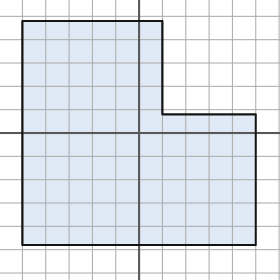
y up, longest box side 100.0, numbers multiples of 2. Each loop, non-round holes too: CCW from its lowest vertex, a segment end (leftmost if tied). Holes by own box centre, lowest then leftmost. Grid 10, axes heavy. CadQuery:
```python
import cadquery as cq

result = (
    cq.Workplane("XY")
    .moveTo(-50.0, -48.0)
    .lineTo(50.0, -48.0)
    .lineTo(50.0, 8.0)
    .lineTo(10.0, 8.0)
    .lineTo(10.0, 48.0)
    .lineTo(-50.0, 48.0)
    .close()
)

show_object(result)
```